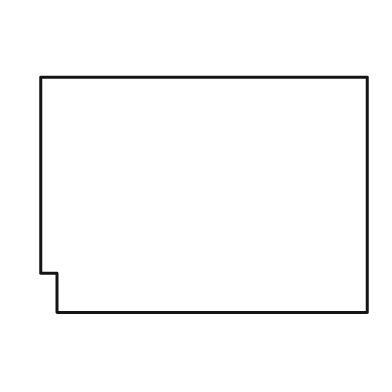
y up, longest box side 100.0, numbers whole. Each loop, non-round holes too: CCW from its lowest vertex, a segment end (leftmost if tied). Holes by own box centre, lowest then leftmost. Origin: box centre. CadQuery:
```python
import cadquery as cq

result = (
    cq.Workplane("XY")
    .moveTo(-45.0, -36.0)
    .lineTo(50.0, -36.0)
    .lineTo(50.0, 36.0)
    .lineTo(-50.0, 36.0)
    .lineTo(-50.0, -24.0)
    .lineTo(-45.0, -24.0)
    .close()
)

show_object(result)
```